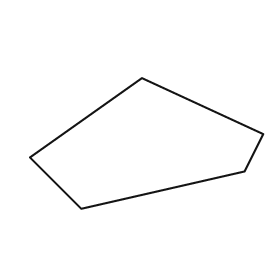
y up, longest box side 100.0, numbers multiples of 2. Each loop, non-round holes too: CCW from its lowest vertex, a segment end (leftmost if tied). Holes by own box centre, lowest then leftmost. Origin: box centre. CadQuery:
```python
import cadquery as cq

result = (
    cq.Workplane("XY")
    .moveTo(-28.0, -28.0)
    .lineTo(42.0, -12.0)
    .lineTo(50.0, 4.0)
    .lineTo(-2.0, 28.0)
    .lineTo(-50.0, -6.0)
    .close()
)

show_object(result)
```